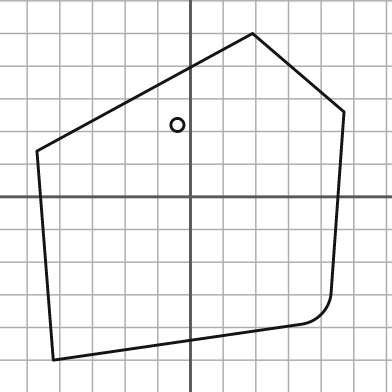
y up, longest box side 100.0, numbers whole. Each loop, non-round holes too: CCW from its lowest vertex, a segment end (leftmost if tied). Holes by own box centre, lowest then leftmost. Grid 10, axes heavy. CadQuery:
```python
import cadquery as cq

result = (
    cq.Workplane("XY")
    .moveTo(-42.0, -50.0)
    .lineTo(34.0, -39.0)
    .threePointArc((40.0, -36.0), (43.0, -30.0))
    .lineTo(47.0, 26.0)
    .lineTo(19.0, 50.0)
    .lineTo(-47.0, 14.0)
    .close()
    .moveTo(-4.0, 22.0)
    .circle(2.0)
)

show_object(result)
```